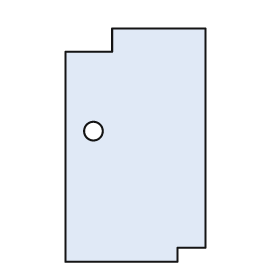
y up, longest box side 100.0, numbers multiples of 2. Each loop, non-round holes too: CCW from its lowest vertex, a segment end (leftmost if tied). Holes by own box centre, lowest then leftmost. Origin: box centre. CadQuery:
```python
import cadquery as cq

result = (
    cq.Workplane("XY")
    .moveTo(-30.0, -50.0)
    .lineTo(18.0, -50.0)
    .lineTo(18.0, -44.0)
    .lineTo(30.0, -44.0)
    .lineTo(30.0, 50.0)
    .lineTo(-10.0, 50.0)
    .lineTo(-10.0, 40.0)
    .lineTo(-30.0, 40.0)
    .close()
    .moveTo(-18.0, 6.0)
    .circle(4.0)
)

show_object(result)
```